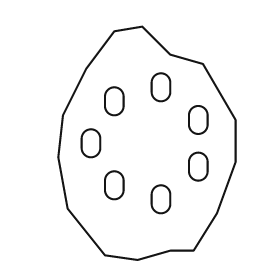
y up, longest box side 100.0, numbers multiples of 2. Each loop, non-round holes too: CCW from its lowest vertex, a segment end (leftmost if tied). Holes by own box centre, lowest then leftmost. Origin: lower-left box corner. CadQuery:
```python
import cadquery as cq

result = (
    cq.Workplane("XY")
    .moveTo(34.0, 0.0)
    .lineTo(48.0, 4.0)
    .lineTo(58.0, 4.0)
    .lineTo(68.0, 20.0)
    .lineTo(76.0, 42.0)
    .lineTo(76.0, 60.0)
    .lineTo(62.0, 84.0)
    .lineTo(48.0, 88.0)
    .lineTo(36.0, 100.0)
    .lineTo(24.0, 98.0)
    .lineTo(12.0, 82.0)
    .lineTo(2.0, 62.0)
    .lineTo(0.0, 44.0)
    .lineTo(4.0, 22.0)
    .lineTo(20.0, 2.0)
    .close()
    .moveTo(40.0, 24.0)
    .threePointArc((44.0, 20.0), (48.0, 24.0))
    .lineTo(48.0, 28.0)
    .threePointArc((44.0, 32.0), (40.0, 28.0))
    .close()
    .moveTo(20.0, 30.0)
    .threePointArc((24.0, 26.0), (28.0, 30.0))
    .lineTo(28.0, 34.0)
    .threePointArc((24.0, 38.0), (20.0, 34.0))
    .close()
    .moveTo(56.0, 38.0)
    .threePointArc((60.0, 34.0), (64.0, 38.0))
    .lineTo(64.0, 42.0)
    .threePointArc((60.0, 46.0), (56.0, 42.0))
    .close()
    .moveTo(10.0, 48.0)
    .threePointArc((14.0, 44.0), (18.0, 48.0))
    .lineTo(18.0, 52.0)
    .threePointArc((14.0, 56.0), (10.0, 52.0))
    .close()
    .moveTo(56.0, 58.0)
    .threePointArc((60.0, 54.0), (64.0, 58.0))
    .lineTo(64.0, 62.0)
    .threePointArc((60.0, 66.0), (56.0, 62.0))
    .close()
    .moveTo(20.0, 66.0)
    .threePointArc((24.0, 62.0), (28.0, 66.0))
    .lineTo(28.0, 70.0)
    .threePointArc((24.0, 74.0), (20.0, 70.0))
    .close()
    .moveTo(40.0, 72.0)
    .threePointArc((44.0, 68.0), (48.0, 72.0))
    .lineTo(48.0, 76.0)
    .threePointArc((44.0, 80.0), (40.0, 76.0))
    .close()
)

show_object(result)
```